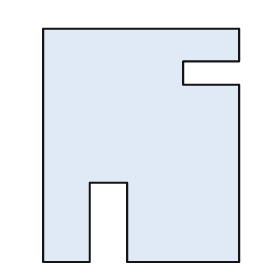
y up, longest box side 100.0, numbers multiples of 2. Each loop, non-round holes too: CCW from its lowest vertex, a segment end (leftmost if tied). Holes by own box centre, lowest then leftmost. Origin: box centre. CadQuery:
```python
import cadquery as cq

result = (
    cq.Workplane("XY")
    .moveTo(-42.0, -50.0)
    .lineTo(-22.0, -50.0)
    .lineTo(-22.0, -16.0)
    .lineTo(-6.0, -16.0)
    .lineTo(-6.0, -50.0)
    .lineTo(42.0, -50.0)
    .lineTo(42.0, 26.0)
    .lineTo(18.0, 26.0)
    .lineTo(18.0, 36.0)
    .lineTo(42.0, 36.0)
    .lineTo(42.0, 50.0)
    .lineTo(-42.0, 50.0)
    .close()
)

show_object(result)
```